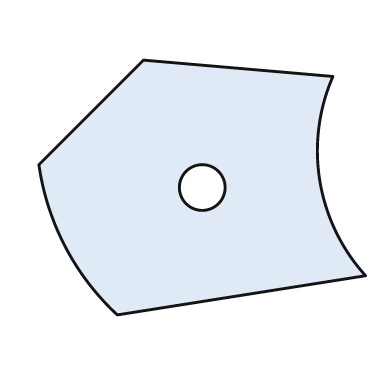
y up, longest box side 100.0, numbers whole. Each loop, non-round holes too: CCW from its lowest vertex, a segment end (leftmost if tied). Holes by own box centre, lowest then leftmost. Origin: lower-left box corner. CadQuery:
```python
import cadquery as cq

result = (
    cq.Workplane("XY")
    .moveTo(24.0, 0.0)
    .lineTo(100.0, 12.0)
    .threePointArc((86.0, 41.0), (90.0, 73.0))
    .lineTo(32.0, 78.0)
    .lineTo(0.0, 46.0)
    .threePointArc((8.0, 21.0), (24.0, 0.0))
    .close()
    .moveTo(50.0, 39.0)
    .circle(7.0)
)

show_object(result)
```